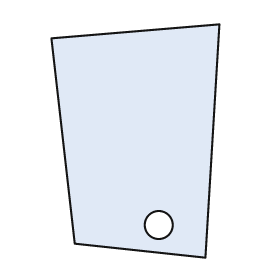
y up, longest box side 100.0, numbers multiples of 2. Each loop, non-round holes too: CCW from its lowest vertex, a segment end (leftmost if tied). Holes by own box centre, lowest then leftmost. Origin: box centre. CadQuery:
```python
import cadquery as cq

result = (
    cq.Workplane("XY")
    .moveTo(30.0, -50.0)
    .lineTo(36.0, 50.0)
    .lineTo(-36.0, 44.0)
    .lineTo(-26.0, -44.0)
    .close()
    .moveTo(10.0, -36.0)
    .circle(6.0)
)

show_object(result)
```